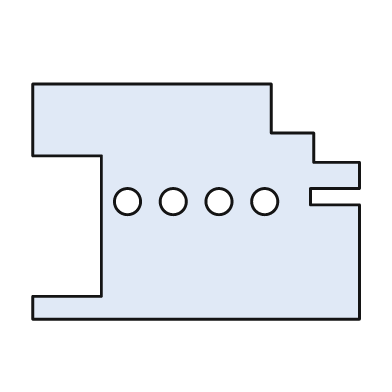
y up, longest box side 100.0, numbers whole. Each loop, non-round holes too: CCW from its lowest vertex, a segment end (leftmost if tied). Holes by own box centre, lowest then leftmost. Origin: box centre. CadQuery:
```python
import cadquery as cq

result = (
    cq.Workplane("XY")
    .moveTo(-50.0, -36.0)
    .lineTo(50.0, -36.0)
    .lineTo(50.0, -1.0)
    .lineTo(35.0, -1.0)
    .lineTo(35.0, 4.0)
    .lineTo(50.0, 4.0)
    .lineTo(50.0, 12.0)
    .lineTo(36.0, 12.0)
    .lineTo(36.0, 21.0)
    .lineTo(23.0, 21.0)
    .lineTo(23.0, 36.0)
    .lineTo(-50.0, 36.0)
    .lineTo(-50.0, 14.0)
    .lineTo(-29.0, 14.0)
    .lineTo(-29.0, -29.0)
    .lineTo(-50.0, -29.0)
    .close()
    .moveTo(-21.0, 0.0)
    .circle(4.0)
    .moveTo(-7.0, 0.0)
    .circle(4.0)
    .moveTo(7.0, 0.0)
    .circle(4.0)
    .moveTo(21.0, 0.0)
    .circle(4.0)
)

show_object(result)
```